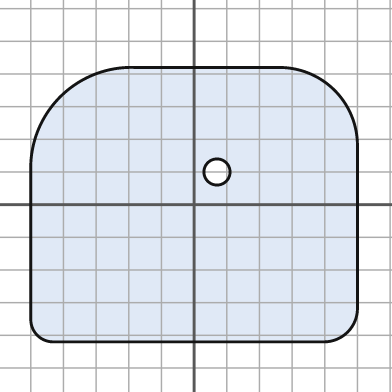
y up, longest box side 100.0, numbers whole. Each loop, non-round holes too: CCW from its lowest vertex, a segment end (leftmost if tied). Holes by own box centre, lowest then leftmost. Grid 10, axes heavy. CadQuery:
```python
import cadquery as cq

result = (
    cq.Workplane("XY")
    .moveTo(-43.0, -42.0)
    .lineTo(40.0, -42.0)
    .threePointArc((47.0, -39.0), (50.0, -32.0))
    .lineTo(50.0, 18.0)
    .threePointArc((43.0, 35.0), (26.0, 42.0))
    .lineTo(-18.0, 42.0)
    .threePointArc((-41.0, 33.0), (-50.0, 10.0))
    .lineTo(-50.0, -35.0)
    .threePointArc((-48.0, -40.0), (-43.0, -42.0))
    .close()
    .moveTo(7.0, 10.0)
    .circle(4.0)
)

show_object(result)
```